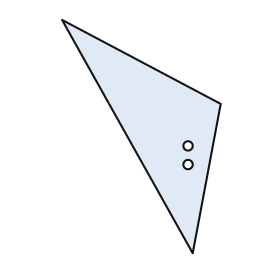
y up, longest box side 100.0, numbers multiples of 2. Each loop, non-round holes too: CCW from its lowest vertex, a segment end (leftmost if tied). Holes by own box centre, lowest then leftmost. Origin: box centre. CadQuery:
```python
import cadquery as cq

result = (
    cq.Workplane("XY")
    .moveTo(22.0, -50.0)
    .lineTo(34.0, 14.0)
    .lineTo(-34.0, 50.0)
    .close()
    .moveTo(20.0, -12.0)
    .circle(2.0)
    .moveTo(20.0, -4.0)
    .circle(2.0)
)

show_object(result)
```